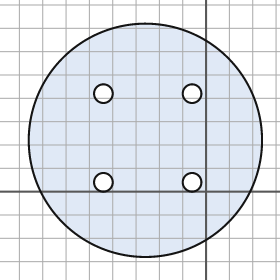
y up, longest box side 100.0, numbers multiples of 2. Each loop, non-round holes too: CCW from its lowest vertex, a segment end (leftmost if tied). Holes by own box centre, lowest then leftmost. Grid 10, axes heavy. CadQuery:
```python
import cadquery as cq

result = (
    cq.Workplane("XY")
    .moveTo(-26.0, 22.0)
    .circle(50.0)
    .moveTo(-44.0, 4.0)
    .circle(4.0)
    .moveTo(-6.0, 4.0)
    .circle(4.0)
    .moveTo(-44.0, 42.0)
    .circle(4.0)
    .moveTo(-6.0, 42.0)
    .circle(4.0)
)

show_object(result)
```